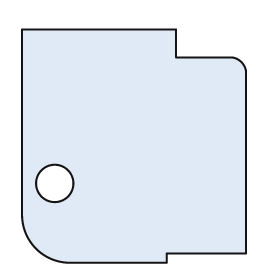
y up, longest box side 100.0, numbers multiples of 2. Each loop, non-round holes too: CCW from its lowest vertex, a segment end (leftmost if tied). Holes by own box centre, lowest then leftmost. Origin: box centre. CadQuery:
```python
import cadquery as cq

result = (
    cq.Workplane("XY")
    .moveTo(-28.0, -50.0)
    .lineTo(14.0, -50.0)
    .lineTo(14.0, -46.0)
    .lineTo(48.0, -46.0)
    .lineTo(48.0, 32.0)
    .threePointArc((46.0, 36.0), (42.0, 38.0))
    .lineTo(18.0, 38.0)
    .lineTo(18.0, 50.0)
    .lineTo(-48.0, 50.0)
    .lineTo(-48.0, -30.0)
    .threePointArc((-42.0, -44.0), (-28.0, -50.0))
    .close()
    .moveTo(-34.0, -16.0)
    .circle(8.0)
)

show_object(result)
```